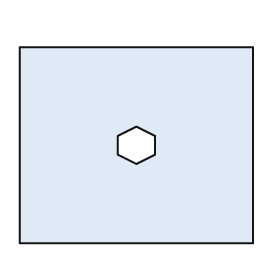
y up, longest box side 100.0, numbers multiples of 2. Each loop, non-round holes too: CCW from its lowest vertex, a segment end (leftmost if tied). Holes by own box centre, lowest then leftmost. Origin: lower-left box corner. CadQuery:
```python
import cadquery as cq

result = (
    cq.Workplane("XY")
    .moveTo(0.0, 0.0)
    .lineTo(100.0, 0.0)
    .lineTo(100.0, 84.0)
    .lineTo(0.0, 84.0)
    .close()
    .moveTo(50.0, 34.0)
    .lineTo(58.0, 38.0)
    .lineTo(58.0, 46.0)
    .lineTo(50.0, 50.0)
    .lineTo(42.0, 46.0)
    .lineTo(42.0, 38.0)
    .close()
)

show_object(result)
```